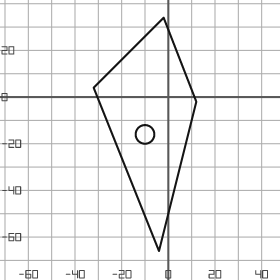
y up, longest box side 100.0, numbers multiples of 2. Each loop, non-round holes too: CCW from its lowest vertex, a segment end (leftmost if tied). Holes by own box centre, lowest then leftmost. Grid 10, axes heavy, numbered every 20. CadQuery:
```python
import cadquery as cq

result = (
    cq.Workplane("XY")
    .moveTo(-4.0, -66.0)
    .lineTo(12.0, -2.0)
    .lineTo(-2.0, 34.0)
    .lineTo(-32.0, 4.0)
    .close()
    .moveTo(-10.0, -16.0)
    .circle(4.0)
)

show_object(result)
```